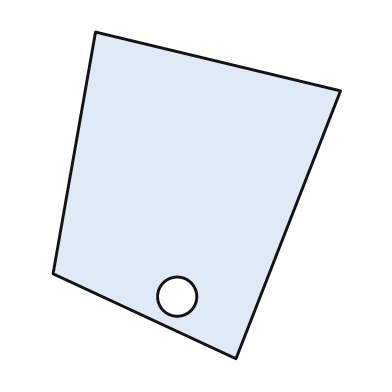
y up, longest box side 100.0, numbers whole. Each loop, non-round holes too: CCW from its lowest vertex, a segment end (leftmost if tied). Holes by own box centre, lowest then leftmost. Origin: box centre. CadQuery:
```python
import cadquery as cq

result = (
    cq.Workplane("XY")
    .moveTo(12.0, -50.0)
    .lineTo(44.0, 32.0)
    .lineTo(-31.0, 50.0)
    .lineTo(-44.0, -24.0)
    .close()
    .moveTo(-6.0, -31.0)
    .circle(6.0)
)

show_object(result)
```